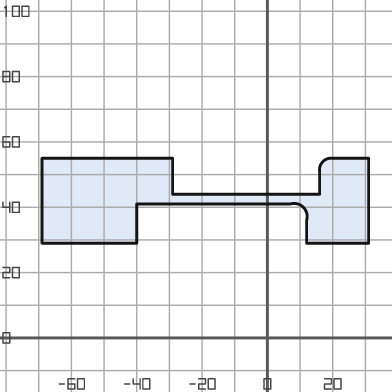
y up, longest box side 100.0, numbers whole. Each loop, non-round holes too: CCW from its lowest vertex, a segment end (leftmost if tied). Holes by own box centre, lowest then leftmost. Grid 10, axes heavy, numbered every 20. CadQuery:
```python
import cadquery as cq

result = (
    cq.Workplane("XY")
    .moveTo(-69.0, 29.0)
    .lineTo(-40.0, 29.0)
    .lineTo(-40.0, 41.0)
    .lineTo(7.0, 41.0)
    .threePointArc((11.0, 40.0), (12.0, 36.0))
    .lineTo(12.0, 29.0)
    .lineTo(31.0, 29.0)
    .lineTo(31.0, 55.0)
    .lineTo(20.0, 55.0)
    .threePointArc((17.0, 54.0), (16.0, 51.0))
    .lineTo(16.0, 44.0)
    .lineTo(-29.0, 44.0)
    .lineTo(-29.0, 55.0)
    .lineTo(-69.0, 55.0)
    .close()
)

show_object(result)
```